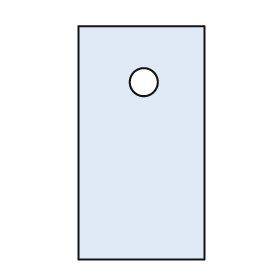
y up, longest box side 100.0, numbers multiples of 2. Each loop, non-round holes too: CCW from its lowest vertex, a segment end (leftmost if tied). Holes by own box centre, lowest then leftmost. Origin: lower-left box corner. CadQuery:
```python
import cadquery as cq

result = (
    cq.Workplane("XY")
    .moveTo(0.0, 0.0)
    .lineTo(54.0, 0.0)
    .lineTo(54.0, 100.0)
    .lineTo(0.0, 100.0)
    .close()
    .moveTo(28.0, 76.0)
    .circle(6.0)
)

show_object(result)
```